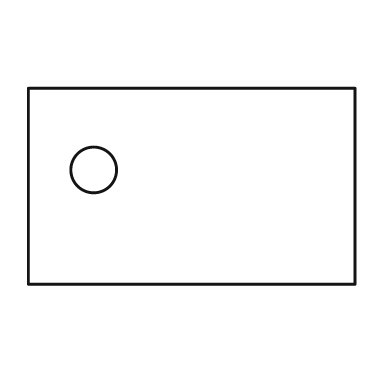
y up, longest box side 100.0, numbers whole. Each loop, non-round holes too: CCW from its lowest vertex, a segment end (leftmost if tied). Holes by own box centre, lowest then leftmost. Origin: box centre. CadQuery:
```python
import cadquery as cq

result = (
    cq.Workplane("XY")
    .moveTo(-50.0, -30.0)
    .lineTo(50.0, -30.0)
    .lineTo(50.0, 30.0)
    .lineTo(-50.0, 30.0)
    .close()
    .moveTo(-30.0, 5.0)
    .circle(7.0)
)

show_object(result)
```